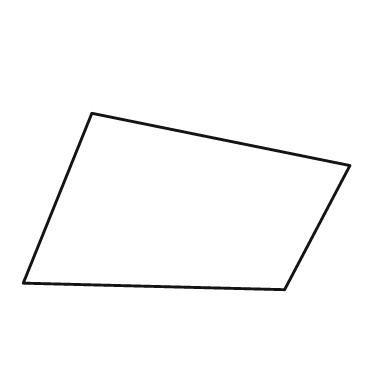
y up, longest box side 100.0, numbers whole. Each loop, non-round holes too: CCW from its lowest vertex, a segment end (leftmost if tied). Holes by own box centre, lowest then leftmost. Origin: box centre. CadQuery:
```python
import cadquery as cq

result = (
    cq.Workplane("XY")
    .moveTo(30.0, -27.0)
    .lineTo(50.0, 11.0)
    .lineTo(-29.0, 27.0)
    .lineTo(-50.0, -25.0)
    .close()
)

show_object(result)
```